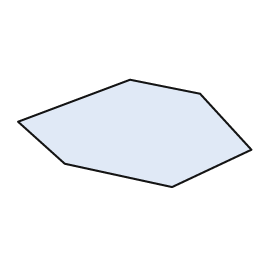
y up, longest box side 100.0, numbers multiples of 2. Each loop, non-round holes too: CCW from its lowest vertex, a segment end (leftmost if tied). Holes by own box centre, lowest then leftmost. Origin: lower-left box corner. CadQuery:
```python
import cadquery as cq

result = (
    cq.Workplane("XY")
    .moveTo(66.0, 0.0)
    .lineTo(100.0, 16.0)
    .lineTo(78.0, 40.0)
    .lineTo(48.0, 46.0)
    .lineTo(0.0, 28.0)
    .lineTo(20.0, 10.0)
    .close()
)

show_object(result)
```